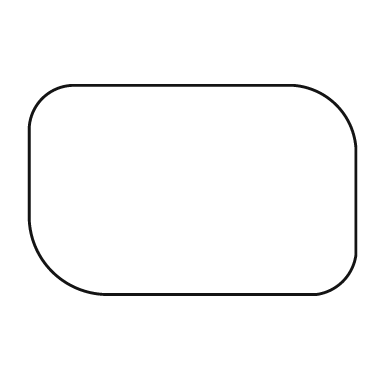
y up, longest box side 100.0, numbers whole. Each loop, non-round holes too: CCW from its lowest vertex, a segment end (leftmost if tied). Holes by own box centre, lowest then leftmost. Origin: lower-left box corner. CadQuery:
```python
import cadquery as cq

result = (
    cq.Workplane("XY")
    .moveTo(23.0, 0.0)
    .lineTo(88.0, 0.0)
    .threePointArc((96.0, 4.0), (100.0, 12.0))
    .lineTo(100.0, 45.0)
    .threePointArc((94.0, 58.0), (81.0, 64.0))
    .lineTo(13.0, 64.0)
    .threePointArc((4.0, 60.0), (0.0, 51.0))
    .lineTo(0.0, 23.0)
    .threePointArc((7.0, 7.0), (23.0, 0.0))
    .close()
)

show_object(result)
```